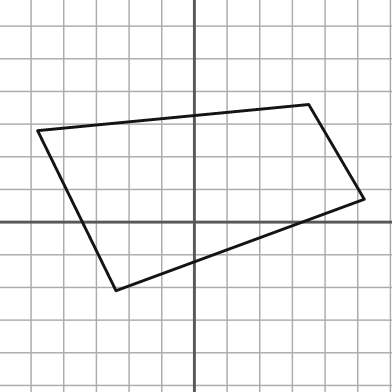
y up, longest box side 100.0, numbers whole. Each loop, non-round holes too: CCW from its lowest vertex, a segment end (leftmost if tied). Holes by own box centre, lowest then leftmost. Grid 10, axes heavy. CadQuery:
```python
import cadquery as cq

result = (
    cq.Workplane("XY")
    .moveTo(-24.0, -21.0)
    .lineTo(52.0, 7.0)
    .lineTo(35.0, 36.0)
    .lineTo(-48.0, 28.0)
    .close()
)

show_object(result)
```